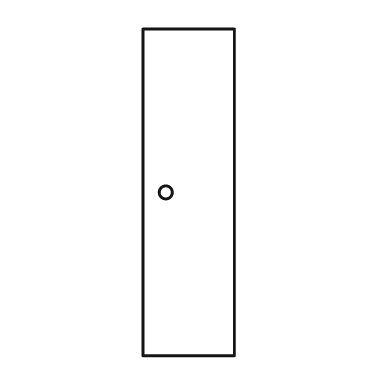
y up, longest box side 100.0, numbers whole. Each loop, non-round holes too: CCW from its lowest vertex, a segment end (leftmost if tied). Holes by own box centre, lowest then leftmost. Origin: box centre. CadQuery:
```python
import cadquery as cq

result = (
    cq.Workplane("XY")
    .moveTo(-14.0, -50.0)
    .lineTo(14.0, -50.0)
    .lineTo(14.0, 50.0)
    .lineTo(-14.0, 50.0)
    .close()
    .moveTo(-7.0, 0.0)
    .circle(2.0)
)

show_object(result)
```